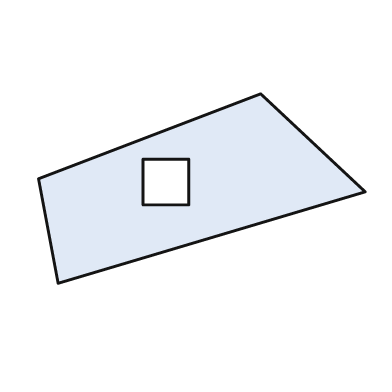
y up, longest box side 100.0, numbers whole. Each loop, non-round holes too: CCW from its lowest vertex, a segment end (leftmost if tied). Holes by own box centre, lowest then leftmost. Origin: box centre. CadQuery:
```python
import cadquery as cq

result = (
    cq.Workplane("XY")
    .moveTo(-44.0, -29.0)
    .lineTo(50.0, -1.0)
    .lineTo(18.0, 29.0)
    .lineTo(-50.0, 3.0)
    .close()
    .moveTo(-18.0, -5.0)
    .lineTo(-4.0, -5.0)
    .lineTo(-4.0, 9.0)
    .lineTo(-18.0, 9.0)
    .close()
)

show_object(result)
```